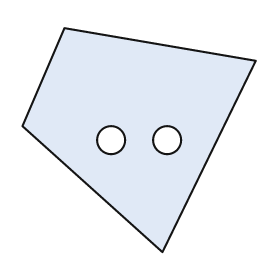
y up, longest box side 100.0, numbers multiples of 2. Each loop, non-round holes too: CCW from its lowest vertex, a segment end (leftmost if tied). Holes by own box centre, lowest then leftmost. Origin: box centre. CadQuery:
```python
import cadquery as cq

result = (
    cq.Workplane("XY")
    .moveTo(10.0, -48.0)
    .lineTo(50.0, 34.0)
    .lineTo(-32.0, 48.0)
    .lineTo(-50.0, 6.0)
    .close()
    .moveTo(-12.0, 0.0)
    .circle(6.0)
    .moveTo(12.0, 0.0)
    .circle(6.0)
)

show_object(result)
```